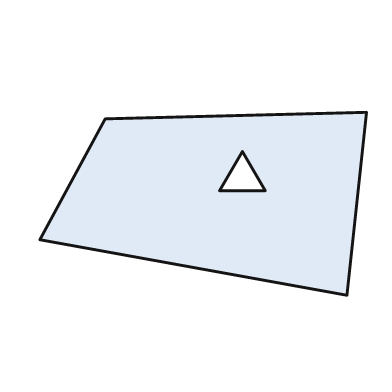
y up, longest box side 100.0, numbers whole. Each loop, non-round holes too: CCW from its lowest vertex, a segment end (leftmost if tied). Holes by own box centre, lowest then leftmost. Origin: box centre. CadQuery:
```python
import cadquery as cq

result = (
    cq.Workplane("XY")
    .moveTo(44.0, -28.0)
    .lineTo(50.0, 28.0)
    .lineTo(-30.0, 26.0)
    .lineTo(-50.0, -11.0)
    .close()
    .moveTo(5.0, 4.0)
    .lineTo(19.0, 4.0)
    .lineTo(12.0, 16.0)
    .close()
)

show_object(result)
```